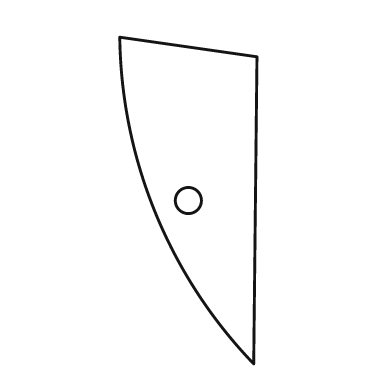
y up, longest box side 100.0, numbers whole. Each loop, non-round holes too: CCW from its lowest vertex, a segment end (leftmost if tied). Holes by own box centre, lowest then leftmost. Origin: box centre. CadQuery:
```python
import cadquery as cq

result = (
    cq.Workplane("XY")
    .moveTo(20.0, -50.0)
    .lineTo(21.0, 44.0)
    .lineTo(-21.0, 50.0)
    .threePointArc((-10.0, -4.0), (20.0, -50.0))
    .close()
    .moveTo(0.0, 0.0)
    .circle(4.0)
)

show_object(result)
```